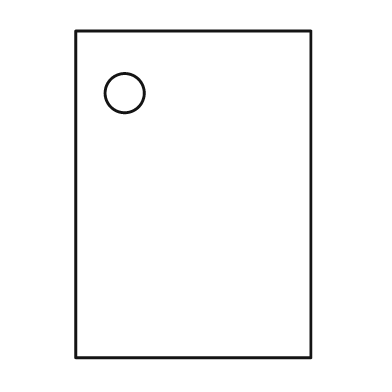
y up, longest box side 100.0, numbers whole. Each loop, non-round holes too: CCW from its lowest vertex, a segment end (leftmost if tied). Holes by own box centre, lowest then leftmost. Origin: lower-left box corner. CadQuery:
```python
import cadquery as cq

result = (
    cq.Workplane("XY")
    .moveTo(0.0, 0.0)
    .lineTo(72.0, 0.0)
    .lineTo(72.0, 100.0)
    .lineTo(0.0, 100.0)
    .close()
    .moveTo(15.0, 81.0)
    .circle(6.0)
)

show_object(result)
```